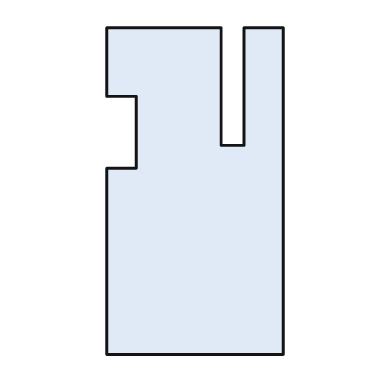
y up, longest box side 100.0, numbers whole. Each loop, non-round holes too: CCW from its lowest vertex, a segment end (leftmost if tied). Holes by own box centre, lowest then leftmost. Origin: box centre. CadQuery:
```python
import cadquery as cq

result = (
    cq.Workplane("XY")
    .moveTo(-27.0, -50.0)
    .lineTo(27.0, -50.0)
    .lineTo(27.0, 50.0)
    .lineTo(15.0, 50.0)
    .lineTo(15.0, 14.0)
    .lineTo(8.0, 14.0)
    .lineTo(8.0, 50.0)
    .lineTo(-27.0, 50.0)
    .lineTo(-27.0, 29.0)
    .lineTo(-18.0, 29.0)
    .lineTo(-18.0, 7.0)
    .lineTo(-27.0, 7.0)
    .close()
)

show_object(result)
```